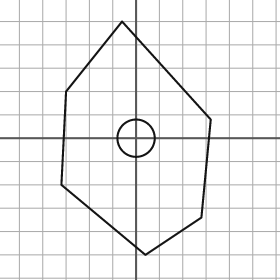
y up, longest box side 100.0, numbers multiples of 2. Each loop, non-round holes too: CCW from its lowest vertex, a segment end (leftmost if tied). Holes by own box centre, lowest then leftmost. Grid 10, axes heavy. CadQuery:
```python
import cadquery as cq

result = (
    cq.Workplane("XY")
    .moveTo(4.0, -50.0)
    .lineTo(28.0, -34.0)
    .lineTo(32.0, 8.0)
    .lineTo(-6.0, 50.0)
    .lineTo(-30.0, 20.0)
    .lineTo(-32.0, -20.0)
    .close()
    .moveTo(0.0, 0.0)
    .circle(8.0)
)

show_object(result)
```